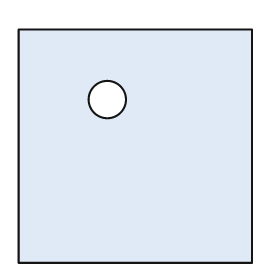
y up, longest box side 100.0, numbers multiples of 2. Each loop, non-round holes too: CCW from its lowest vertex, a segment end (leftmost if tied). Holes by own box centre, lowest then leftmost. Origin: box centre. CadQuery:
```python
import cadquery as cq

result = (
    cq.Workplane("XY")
    .moveTo(-50.0, -50.0)
    .lineTo(50.0, -50.0)
    .lineTo(50.0, 50.0)
    .lineTo(-50.0, 50.0)
    .close()
    .moveTo(-12.0, 20.0)
    .circle(8.0)
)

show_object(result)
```